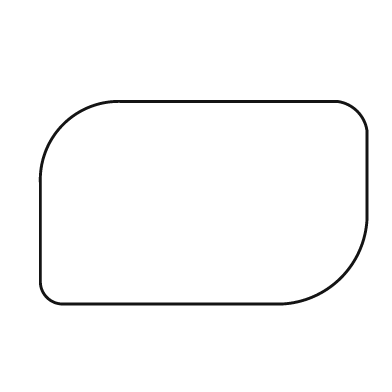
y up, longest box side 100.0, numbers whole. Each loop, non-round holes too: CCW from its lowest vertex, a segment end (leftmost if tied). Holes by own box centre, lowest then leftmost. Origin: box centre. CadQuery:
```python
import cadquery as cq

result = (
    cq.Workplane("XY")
    .moveTo(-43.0, -31.0)
    .lineTo(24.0, -31.0)
    .threePointArc((42.0, -23.0), (50.0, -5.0))
    .lineTo(50.0, 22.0)
    .threePointArc((47.0, 28.0), (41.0, 31.0))
    .lineTo(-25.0, 31.0)
    .threePointArc((-43.0, 24.0), (-50.0, 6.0))
    .lineTo(-50.0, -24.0)
    .threePointArc((-48.0, -29.0), (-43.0, -31.0))
    .close()
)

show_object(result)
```